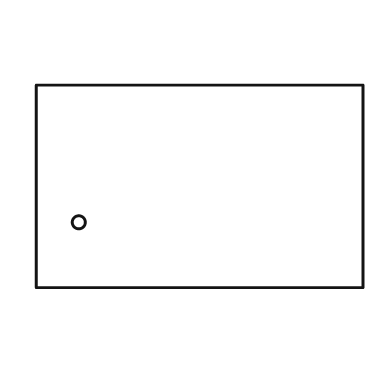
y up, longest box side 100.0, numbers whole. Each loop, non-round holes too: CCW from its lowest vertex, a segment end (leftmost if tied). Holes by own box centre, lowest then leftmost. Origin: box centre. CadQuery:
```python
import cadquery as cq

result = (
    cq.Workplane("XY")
    .moveTo(-50.0, -31.0)
    .lineTo(50.0, -31.0)
    .lineTo(50.0, 31.0)
    .lineTo(-50.0, 31.0)
    .close()
    .moveTo(-37.0, -11.0)
    .circle(2.0)
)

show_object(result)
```